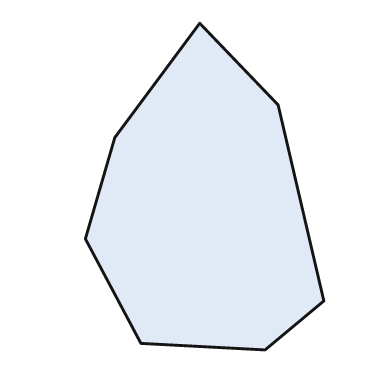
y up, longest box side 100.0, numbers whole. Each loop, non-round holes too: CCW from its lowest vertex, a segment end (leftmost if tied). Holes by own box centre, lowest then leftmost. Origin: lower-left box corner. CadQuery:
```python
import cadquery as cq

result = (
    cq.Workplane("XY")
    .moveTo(55.0, 0.0)
    .lineTo(73.0, 15.0)
    .lineTo(59.0, 75.0)
    .lineTo(35.0, 100.0)
    .lineTo(9.0, 65.0)
    .lineTo(0.0, 34.0)
    .lineTo(17.0, 2.0)
    .close()
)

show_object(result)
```